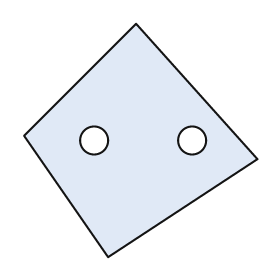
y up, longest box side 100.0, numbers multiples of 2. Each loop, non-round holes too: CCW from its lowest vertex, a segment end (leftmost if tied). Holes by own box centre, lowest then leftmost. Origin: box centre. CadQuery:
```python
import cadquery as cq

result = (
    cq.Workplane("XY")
    .moveTo(-14.0, -50.0)
    .lineTo(50.0, -8.0)
    .lineTo(-2.0, 50.0)
    .lineTo(-50.0, 2.0)
    .close()
    .moveTo(-20.0, 0.0)
    .circle(6.0)
    .moveTo(22.0, 0.0)
    .circle(6.0)
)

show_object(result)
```